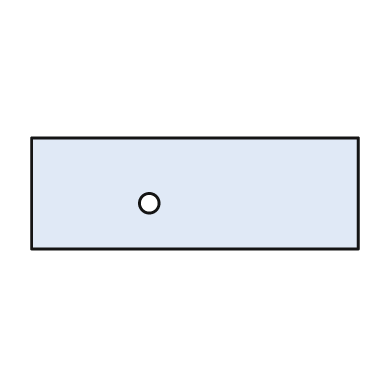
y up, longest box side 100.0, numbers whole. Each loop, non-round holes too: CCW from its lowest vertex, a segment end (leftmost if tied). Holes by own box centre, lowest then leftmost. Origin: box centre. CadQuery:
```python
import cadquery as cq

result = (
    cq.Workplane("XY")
    .moveTo(-50.0, -17.0)
    .lineTo(50.0, -17.0)
    .lineTo(50.0, 17.0)
    .lineTo(-50.0, 17.0)
    .close()
    .moveTo(-14.0, -3.0)
    .circle(3.0)
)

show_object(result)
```